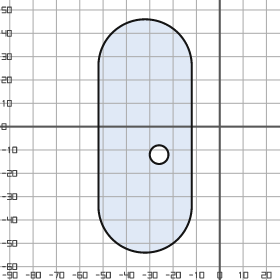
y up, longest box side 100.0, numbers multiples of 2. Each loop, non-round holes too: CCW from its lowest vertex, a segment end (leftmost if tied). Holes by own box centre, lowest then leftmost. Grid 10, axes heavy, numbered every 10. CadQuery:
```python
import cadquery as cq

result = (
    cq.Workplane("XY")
    .moveTo(-52.0, -34.0)
    .threePointArc((-32.0, -54.0), (-12.0, -34.0))
    .lineTo(-12.0, 26.0)
    .threePointArc((-32.0, 46.0), (-52.0, 26.0))
    .close()
    .moveTo(-26.0, -12.0)
    .circle(4.0)
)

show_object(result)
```